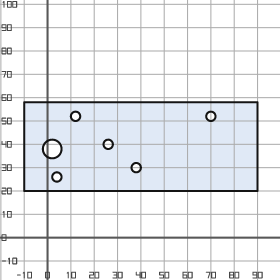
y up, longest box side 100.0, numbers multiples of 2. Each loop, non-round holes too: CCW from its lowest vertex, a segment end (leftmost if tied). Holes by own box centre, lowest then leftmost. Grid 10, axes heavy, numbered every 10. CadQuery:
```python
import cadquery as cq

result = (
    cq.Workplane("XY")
    .moveTo(-10.0, 20.0)
    .lineTo(90.0, 20.0)
    .lineTo(90.0, 58.0)
    .lineTo(-10.0, 58.0)
    .close()
    .moveTo(4.0, 26.0)
    .circle(2.0)
    .moveTo(38.0, 30.0)
    .circle(2.0)
    .moveTo(2.0, 38.0)
    .circle(4.0)
    .moveTo(26.0, 40.0)
    .circle(2.0)
    .moveTo(12.0, 52.0)
    .circle(2.0)
    .moveTo(70.0, 52.0)
    .circle(2.0)
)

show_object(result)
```